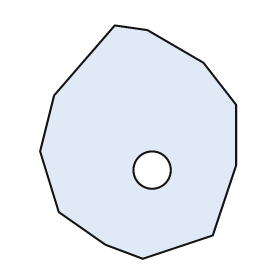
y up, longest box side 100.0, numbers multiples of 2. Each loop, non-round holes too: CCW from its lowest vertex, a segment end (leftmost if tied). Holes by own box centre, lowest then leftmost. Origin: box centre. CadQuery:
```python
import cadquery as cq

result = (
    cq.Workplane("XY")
    .moveTo(2.0, -50.0)
    .lineTo(32.0, -40.0)
    .lineTo(42.0, -10.0)
    .lineTo(42.0, 16.0)
    .lineTo(28.0, 34.0)
    .lineTo(4.0, 48.0)
    .lineTo(-10.0, 50.0)
    .lineTo(-36.0, 20.0)
    .lineTo(-42.0, -4.0)
    .lineTo(-34.0, -30.0)
    .lineTo(-14.0, -44.0)
    .close()
    .moveTo(6.0, -12.0)
    .circle(8.0)
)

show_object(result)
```